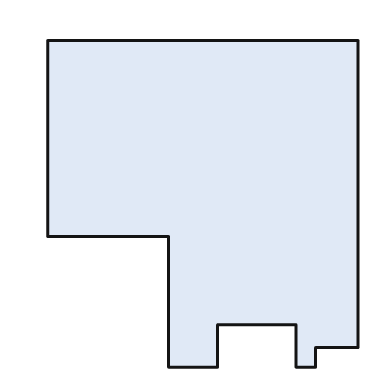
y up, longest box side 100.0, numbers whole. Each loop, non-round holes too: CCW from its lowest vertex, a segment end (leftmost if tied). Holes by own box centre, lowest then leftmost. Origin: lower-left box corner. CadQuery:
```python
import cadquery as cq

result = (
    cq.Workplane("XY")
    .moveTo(37.0, 0.0)
    .lineTo(52.0, 0.0)
    .lineTo(52.0, 13.0)
    .lineTo(76.0, 13.0)
    .lineTo(76.0, 0.0)
    .lineTo(82.0, 0.0)
    .lineTo(82.0, 6.0)
    .lineTo(95.0, 6.0)
    .lineTo(95.0, 100.0)
    .lineTo(0.0, 100.0)
    .lineTo(0.0, 40.0)
    .lineTo(37.0, 40.0)
    .close()
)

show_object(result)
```